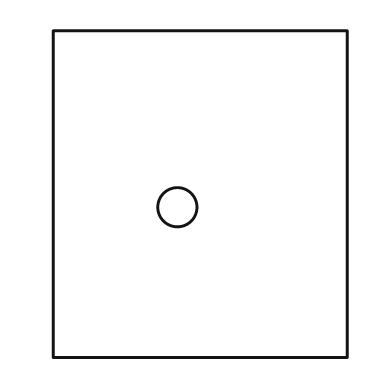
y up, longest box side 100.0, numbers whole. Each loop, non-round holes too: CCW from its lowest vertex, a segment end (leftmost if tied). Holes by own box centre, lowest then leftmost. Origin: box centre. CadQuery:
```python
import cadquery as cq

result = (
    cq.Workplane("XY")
    .moveTo(-45.0, -50.0)
    .lineTo(45.0, -50.0)
    .lineTo(45.0, 50.0)
    .lineTo(-45.0, 50.0)
    .close()
    .moveTo(-7.0, -4.0)
    .circle(6.0)
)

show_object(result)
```